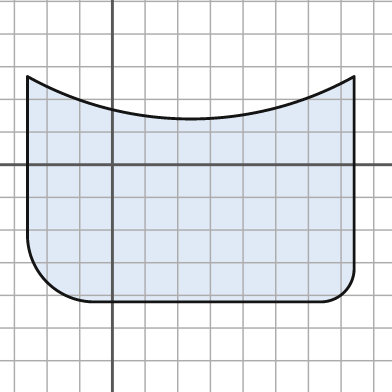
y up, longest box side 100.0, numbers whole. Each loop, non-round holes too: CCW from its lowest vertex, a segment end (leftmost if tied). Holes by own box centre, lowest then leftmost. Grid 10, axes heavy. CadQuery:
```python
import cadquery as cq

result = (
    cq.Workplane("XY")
    .moveTo(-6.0, -42.0)
    .lineTo(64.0, -42.0)
    .threePointArc((71.0, -39.0), (74.0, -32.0))
    .lineTo(74.0, 27.0)
    .threePointArc((24.0, 14.0), (-26.0, 27.0))
    .lineTo(-26.0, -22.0)
    .threePointArc((-20.0, -36.0), (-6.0, -42.0))
    .close()
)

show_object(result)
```